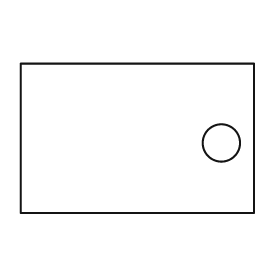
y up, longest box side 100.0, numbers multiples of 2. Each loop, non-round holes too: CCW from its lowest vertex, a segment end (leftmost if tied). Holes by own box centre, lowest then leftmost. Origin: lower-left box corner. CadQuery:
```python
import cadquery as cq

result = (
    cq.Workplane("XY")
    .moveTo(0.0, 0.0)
    .lineTo(100.0, 0.0)
    .lineTo(100.0, 64.0)
    .lineTo(0.0, 64.0)
    .close()
    .moveTo(86.0, 30.0)
    .circle(8.0)
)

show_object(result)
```